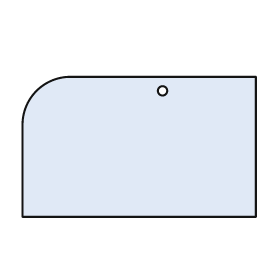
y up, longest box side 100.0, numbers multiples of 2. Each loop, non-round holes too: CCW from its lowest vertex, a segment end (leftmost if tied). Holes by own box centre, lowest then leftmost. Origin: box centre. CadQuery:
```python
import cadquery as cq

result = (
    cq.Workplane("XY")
    .moveTo(-50.0, -30.0)
    .lineTo(50.0, -30.0)
    .lineTo(50.0, 30.0)
    .lineTo(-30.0, 30.0)
    .threePointArc((-44.0, 24.0), (-50.0, 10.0))
    .close()
    .moveTo(10.0, 24.0)
    .circle(2.0)
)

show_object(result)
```